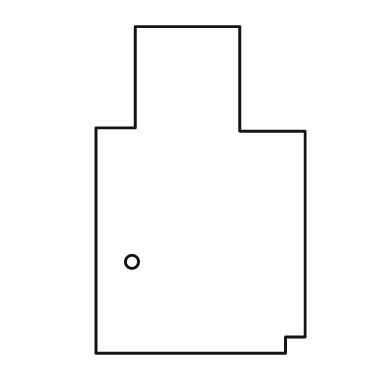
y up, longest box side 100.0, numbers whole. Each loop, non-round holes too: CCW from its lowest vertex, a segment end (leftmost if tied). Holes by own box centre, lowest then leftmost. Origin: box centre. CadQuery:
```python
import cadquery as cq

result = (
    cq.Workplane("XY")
    .moveTo(-32.0, -50.0)
    .lineTo(26.0, -50.0)
    .lineTo(26.0, -45.0)
    .lineTo(32.0, -45.0)
    .lineTo(32.0, 18.0)
    .lineTo(12.0, 18.0)
    .lineTo(12.0, 50.0)
    .lineTo(-20.0, 50.0)
    .lineTo(-20.0, 19.0)
    .lineTo(-32.0, 19.0)
    .close()
    .moveTo(-21.0, -22.0)
    .circle(2.0)
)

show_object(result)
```